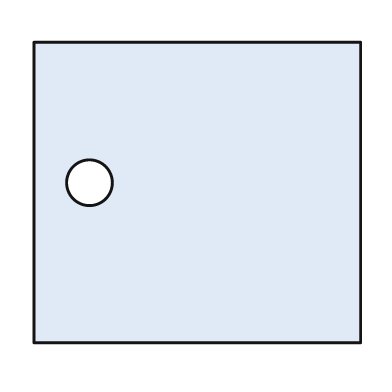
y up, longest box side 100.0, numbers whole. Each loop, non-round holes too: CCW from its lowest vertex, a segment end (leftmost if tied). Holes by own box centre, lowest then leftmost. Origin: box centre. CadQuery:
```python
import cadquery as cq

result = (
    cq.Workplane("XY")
    .moveTo(-50.0, -46.0)
    .lineTo(50.0, -46.0)
    .lineTo(50.0, 46.0)
    .lineTo(-50.0, 46.0)
    .close()
    .moveTo(-33.0, 3.0)
    .circle(7.0)
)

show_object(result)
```